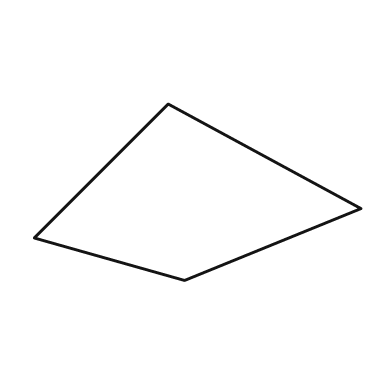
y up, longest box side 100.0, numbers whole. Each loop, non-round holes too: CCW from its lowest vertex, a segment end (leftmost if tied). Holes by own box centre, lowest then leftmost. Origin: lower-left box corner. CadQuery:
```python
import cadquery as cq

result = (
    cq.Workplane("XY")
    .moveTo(46.0, 0.0)
    .lineTo(100.0, 22.0)
    .lineTo(41.0, 54.0)
    .lineTo(0.0, 13.0)
    .close()
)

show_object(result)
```